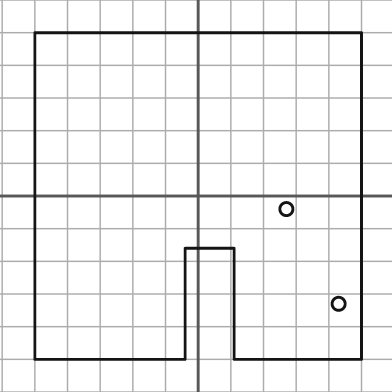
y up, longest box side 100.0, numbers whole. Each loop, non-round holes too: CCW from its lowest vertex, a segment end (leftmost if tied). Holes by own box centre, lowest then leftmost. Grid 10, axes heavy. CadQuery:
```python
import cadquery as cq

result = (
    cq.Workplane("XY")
    .moveTo(-50.0, -50.0)
    .lineTo(-4.0, -50.0)
    .lineTo(-4.0, -16.0)
    .lineTo(11.0, -16.0)
    .lineTo(11.0, -50.0)
    .lineTo(50.0, -50.0)
    .lineTo(50.0, 50.0)
    .lineTo(-50.0, 50.0)
    .close()
    .moveTo(43.0, -33.0)
    .circle(2.0)
    .moveTo(27.0, -4.0)
    .circle(2.0)
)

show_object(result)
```